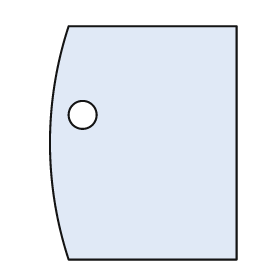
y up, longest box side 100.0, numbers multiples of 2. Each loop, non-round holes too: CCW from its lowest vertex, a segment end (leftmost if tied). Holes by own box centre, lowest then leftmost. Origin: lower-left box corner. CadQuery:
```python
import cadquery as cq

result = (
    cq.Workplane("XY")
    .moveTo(8.0, 0.0)
    .lineTo(80.0, 0.0)
    .lineTo(80.0, 100.0)
    .lineTo(8.0, 100.0)
    .threePointArc((0.0, 50.0), (8.0, 0.0))
    .close()
    .moveTo(14.0, 62.0)
    .circle(6.0)
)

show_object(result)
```